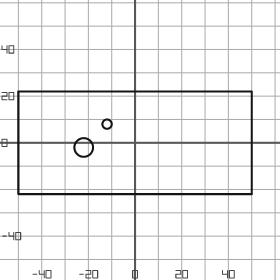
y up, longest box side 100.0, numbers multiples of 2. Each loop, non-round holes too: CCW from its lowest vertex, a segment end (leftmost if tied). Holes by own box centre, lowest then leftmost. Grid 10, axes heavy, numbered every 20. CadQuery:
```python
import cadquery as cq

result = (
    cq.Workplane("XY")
    .moveTo(-50.0, -22.0)
    .lineTo(50.0, -22.0)
    .lineTo(50.0, 22.0)
    .lineTo(-50.0, 22.0)
    .close()
    .moveTo(-22.0, -2.0)
    .circle(4.0)
    .moveTo(-12.0, 8.0)
    .circle(2.0)
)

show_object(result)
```